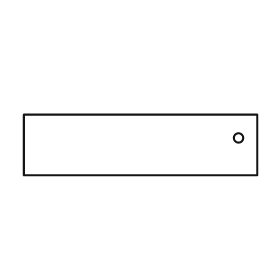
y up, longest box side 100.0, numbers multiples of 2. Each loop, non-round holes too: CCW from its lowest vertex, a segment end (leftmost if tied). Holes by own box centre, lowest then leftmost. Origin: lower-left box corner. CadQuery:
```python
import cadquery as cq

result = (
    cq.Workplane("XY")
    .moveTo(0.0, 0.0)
    .lineTo(100.0, 0.0)
    .lineTo(100.0, 26.0)
    .lineTo(0.0, 26.0)
    .close()
    .moveTo(92.0, 16.0)
    .circle(2.0)
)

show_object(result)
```